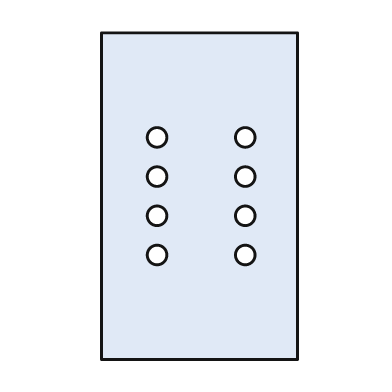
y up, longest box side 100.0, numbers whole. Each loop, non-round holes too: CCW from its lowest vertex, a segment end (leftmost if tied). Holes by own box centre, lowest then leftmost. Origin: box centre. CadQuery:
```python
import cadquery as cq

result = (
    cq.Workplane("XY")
    .moveTo(-30.0, -50.0)
    .lineTo(30.0, -50.0)
    .lineTo(30.0, 50.0)
    .lineTo(-30.0, 50.0)
    .close()
    .moveTo(-13.0, -18.0)
    .circle(3.0)
    .moveTo(14.0, -18.0)
    .circle(3.0)
    .moveTo(-13.0, -6.0)
    .circle(3.0)
    .moveTo(14.0, -6.0)
    .circle(3.0)
    .moveTo(-13.0, 6.0)
    .circle(3.0)
    .moveTo(14.0, 6.0)
    .circle(3.0)
    .moveTo(-13.0, 18.0)
    .circle(3.0)
    .moveTo(14.0, 18.0)
    .circle(3.0)
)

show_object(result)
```